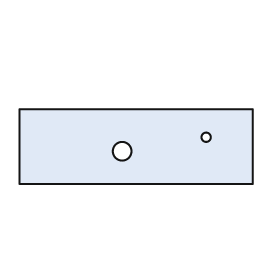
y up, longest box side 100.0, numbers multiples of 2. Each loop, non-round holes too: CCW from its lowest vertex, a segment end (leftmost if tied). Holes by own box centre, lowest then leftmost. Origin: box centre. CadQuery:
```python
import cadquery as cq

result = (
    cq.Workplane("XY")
    .moveTo(-50.0, -16.0)
    .lineTo(50.0, -16.0)
    .lineTo(50.0, 16.0)
    .lineTo(-50.0, 16.0)
    .close()
    .moveTo(-6.0, -2.0)
    .circle(4.0)
    .moveTo(30.0, 4.0)
    .circle(2.0)
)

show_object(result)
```